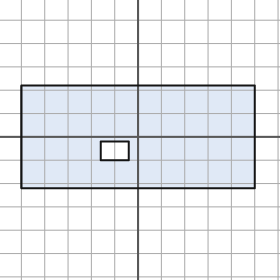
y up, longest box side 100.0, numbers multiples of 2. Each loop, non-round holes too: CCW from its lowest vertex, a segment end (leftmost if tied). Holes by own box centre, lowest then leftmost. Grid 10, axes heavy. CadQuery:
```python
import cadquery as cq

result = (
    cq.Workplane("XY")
    .moveTo(-50.0, -22.0)
    .lineTo(50.0, -22.0)
    .lineTo(50.0, 22.0)
    .lineTo(-50.0, 22.0)
    .close()
    .moveTo(-16.0, -10.0)
    .lineTo(-4.0, -10.0)
    .lineTo(-4.0, -2.0)
    .lineTo(-16.0, -2.0)
    .close()
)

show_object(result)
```